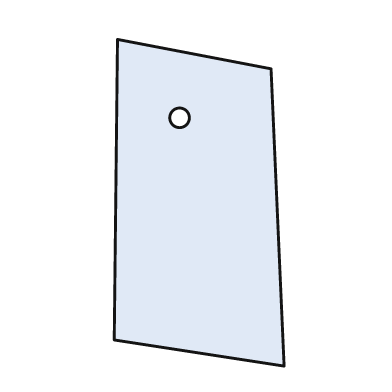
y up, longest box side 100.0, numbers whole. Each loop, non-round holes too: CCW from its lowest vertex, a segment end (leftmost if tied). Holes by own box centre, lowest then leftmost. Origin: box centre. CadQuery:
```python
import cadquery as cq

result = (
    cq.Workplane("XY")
    .moveTo(26.0, -50.0)
    .lineTo(22.0, 41.0)
    .lineTo(-25.0, 50.0)
    .lineTo(-26.0, -42.0)
    .close()
    .moveTo(-6.0, 26.0)
    .circle(3.0)
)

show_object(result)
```